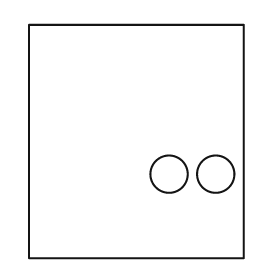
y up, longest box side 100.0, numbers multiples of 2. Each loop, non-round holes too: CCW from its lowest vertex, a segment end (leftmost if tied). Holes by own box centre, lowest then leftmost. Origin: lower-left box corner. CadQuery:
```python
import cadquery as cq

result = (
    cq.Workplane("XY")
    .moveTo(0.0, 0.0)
    .lineTo(92.0, 0.0)
    .lineTo(92.0, 100.0)
    .lineTo(0.0, 100.0)
    .close()
    .moveTo(60.0, 36.0)
    .circle(8.0)
    .moveTo(80.0, 36.0)
    .circle(8.0)
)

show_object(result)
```